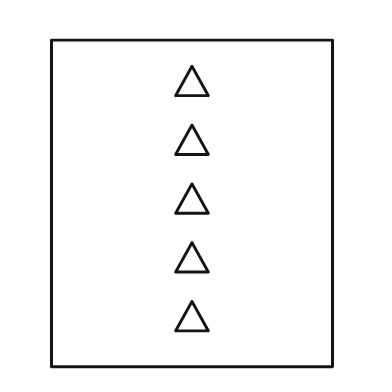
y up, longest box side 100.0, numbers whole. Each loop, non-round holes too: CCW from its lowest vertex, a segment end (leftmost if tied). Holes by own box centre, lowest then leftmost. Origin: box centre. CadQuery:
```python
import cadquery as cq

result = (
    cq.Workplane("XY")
    .moveTo(-43.0, -50.0)
    .lineTo(43.0, -50.0)
    .lineTo(43.0, 50.0)
    .lineTo(-43.0, 50.0)
    .close()
    .moveTo(-5.0, -39.0)
    .lineTo(5.0, -39.0)
    .lineTo(0.0, -30.0)
    .close()
    .moveTo(-5.0, -21.0)
    .lineTo(5.0, -21.0)
    .lineTo(0.0, -12.0)
    .close()
    .moveTo(-5.0, -3.0)
    .lineTo(5.0, -3.0)
    .lineTo(0.0, 6.0)
    .close()
    .moveTo(-5.0, 15.0)
    .lineTo(5.0, 15.0)
    .lineTo(0.0, 24.0)
    .close()
    .moveTo(-5.0, 33.0)
    .lineTo(5.0, 33.0)
    .lineTo(0.0, 42.0)
    .close()
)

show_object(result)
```